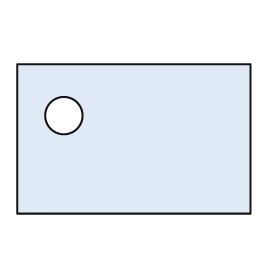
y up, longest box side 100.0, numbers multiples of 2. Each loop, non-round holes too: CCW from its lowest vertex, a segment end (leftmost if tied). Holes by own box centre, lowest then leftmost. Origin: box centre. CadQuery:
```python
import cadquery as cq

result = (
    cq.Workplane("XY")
    .moveTo(-50.0, -32.0)
    .lineTo(50.0, -32.0)
    .lineTo(50.0, 32.0)
    .lineTo(-50.0, 32.0)
    .close()
    .moveTo(-30.0, 10.0)
    .circle(8.0)
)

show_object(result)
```